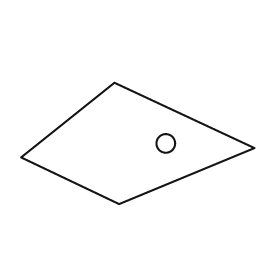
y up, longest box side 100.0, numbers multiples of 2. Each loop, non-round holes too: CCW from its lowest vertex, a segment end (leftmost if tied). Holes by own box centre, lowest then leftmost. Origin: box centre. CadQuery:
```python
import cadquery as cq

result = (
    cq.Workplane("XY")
    .moveTo(-8.0, -26.0)
    .lineTo(50.0, -2.0)
    .lineTo(-10.0, 26.0)
    .lineTo(-50.0, -6.0)
    .close()
    .moveTo(12.0, 0.0)
    .circle(4.0)
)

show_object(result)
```